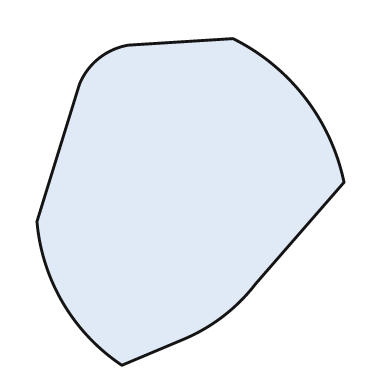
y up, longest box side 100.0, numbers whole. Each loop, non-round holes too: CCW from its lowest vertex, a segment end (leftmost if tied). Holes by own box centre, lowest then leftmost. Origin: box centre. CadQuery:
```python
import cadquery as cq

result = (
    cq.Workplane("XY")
    .moveTo(-21.0, -50.0)
    .lineTo(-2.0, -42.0)
    .threePointArc((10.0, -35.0), (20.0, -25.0))
    .lineTo(47.0, 6.0)
    .threePointArc((35.0, 32.0), (13.0, 50.0))
    .lineTo(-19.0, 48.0)
    .threePointArc((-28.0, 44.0), (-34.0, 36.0))
    .lineTo(-47.0, -6.0)
    .threePointArc((-39.0, -31.0), (-21.0, -50.0))
    .close()
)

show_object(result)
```